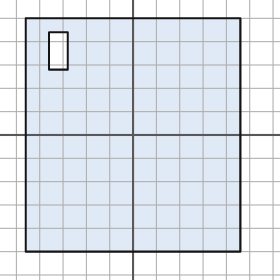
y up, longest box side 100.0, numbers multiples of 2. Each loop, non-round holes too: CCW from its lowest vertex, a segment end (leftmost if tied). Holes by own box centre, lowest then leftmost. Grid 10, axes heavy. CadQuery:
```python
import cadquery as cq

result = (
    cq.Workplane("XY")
    .moveTo(-46.0, -50.0)
    .lineTo(46.0, -50.0)
    .lineTo(46.0, 50.0)
    .lineTo(-46.0, 50.0)
    .close()
    .moveTo(-36.0, 28.0)
    .lineTo(-28.0, 28.0)
    .lineTo(-28.0, 44.0)
    .lineTo(-36.0, 44.0)
    .close()
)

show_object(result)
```